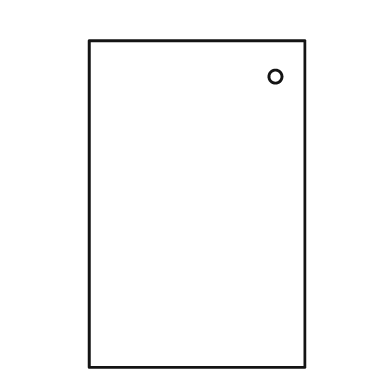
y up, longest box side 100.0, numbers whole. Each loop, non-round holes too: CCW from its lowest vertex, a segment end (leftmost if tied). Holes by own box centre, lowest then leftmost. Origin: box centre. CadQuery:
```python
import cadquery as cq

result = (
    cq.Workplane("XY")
    .moveTo(-33.0, -50.0)
    .lineTo(33.0, -50.0)
    .lineTo(33.0, 50.0)
    .lineTo(-33.0, 50.0)
    .close()
    .moveTo(24.0, 39.0)
    .circle(2.0)
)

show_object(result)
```